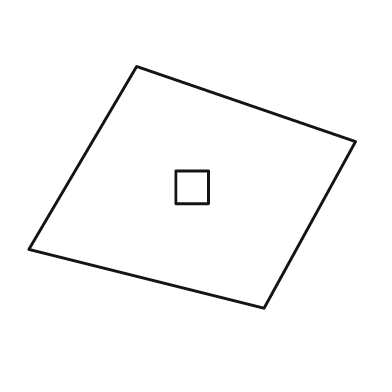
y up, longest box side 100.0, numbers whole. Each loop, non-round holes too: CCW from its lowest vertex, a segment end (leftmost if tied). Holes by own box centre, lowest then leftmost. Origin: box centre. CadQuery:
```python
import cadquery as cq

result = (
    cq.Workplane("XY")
    .moveTo(22.0, -37.0)
    .lineTo(50.0, 14.0)
    .lineTo(-17.0, 37.0)
    .lineTo(-50.0, -19.0)
    .close()
    .moveTo(-5.0, -5.0)
    .lineTo(5.0, -5.0)
    .lineTo(5.0, 5.0)
    .lineTo(-5.0, 5.0)
    .close()
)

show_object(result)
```